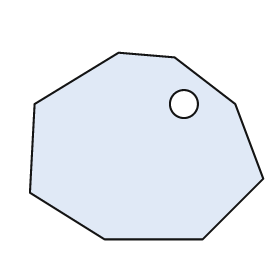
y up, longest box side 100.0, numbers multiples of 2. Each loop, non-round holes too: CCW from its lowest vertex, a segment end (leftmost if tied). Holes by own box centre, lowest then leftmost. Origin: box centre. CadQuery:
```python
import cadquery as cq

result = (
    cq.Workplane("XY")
    .moveTo(-18.0, -40.0)
    .lineTo(24.0, -40.0)
    .lineTo(50.0, -14.0)
    .lineTo(38.0, 18.0)
    .lineTo(12.0, 38.0)
    .lineTo(-12.0, 40.0)
    .lineTo(-48.0, 18.0)
    .lineTo(-50.0, -20.0)
    .close()
    .moveTo(16.0, 18.0)
    .circle(6.0)
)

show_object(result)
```